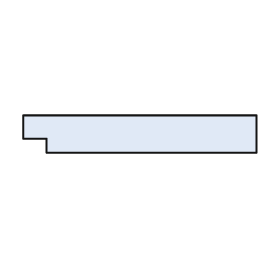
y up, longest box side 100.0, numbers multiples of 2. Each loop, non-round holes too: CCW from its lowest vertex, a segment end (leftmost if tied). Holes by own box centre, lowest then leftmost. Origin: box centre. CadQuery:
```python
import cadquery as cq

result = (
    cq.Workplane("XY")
    .moveTo(-40.0, -8.0)
    .lineTo(50.0, -8.0)
    .lineTo(50.0, 8.0)
    .lineTo(-50.0, 8.0)
    .lineTo(-50.0, -2.0)
    .lineTo(-40.0, -2.0)
    .close()
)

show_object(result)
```